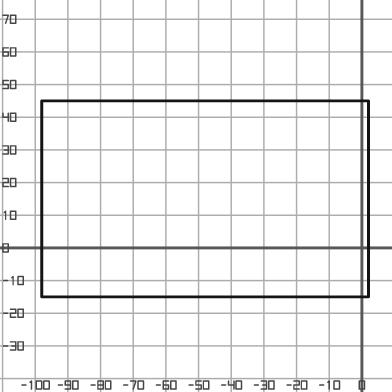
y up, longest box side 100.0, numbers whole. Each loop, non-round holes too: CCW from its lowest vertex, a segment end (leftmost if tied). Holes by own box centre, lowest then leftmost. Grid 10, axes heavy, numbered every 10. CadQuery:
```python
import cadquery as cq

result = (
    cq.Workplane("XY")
    .moveTo(-98.0, -15.0)
    .lineTo(2.0, -15.0)
    .lineTo(2.0, 45.0)
    .lineTo(-98.0, 45.0)
    .close()
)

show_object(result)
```